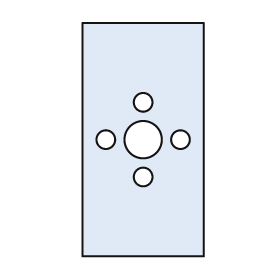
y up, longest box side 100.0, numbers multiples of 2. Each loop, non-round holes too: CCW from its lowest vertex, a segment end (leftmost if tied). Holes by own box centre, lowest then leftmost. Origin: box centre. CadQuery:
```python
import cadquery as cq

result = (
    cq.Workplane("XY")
    .moveTo(-26.0, -50.0)
    .lineTo(26.0, -50.0)
    .lineTo(26.0, 50.0)
    .lineTo(-26.0, 50.0)
    .close()
    .moveTo(0.0, -16.0)
    .circle(4.0)
    .moveTo(-16.0, 0.0)
    .circle(4.0)
    .moveTo(0.0, 0.0)
    .circle(8.0)
    .moveTo(16.0, 0.0)
    .circle(4.0)
    .moveTo(0.0, 16.0)
    .circle(4.0)
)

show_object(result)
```